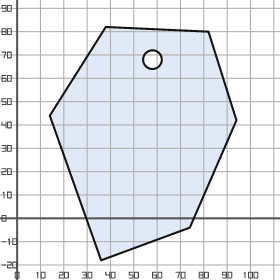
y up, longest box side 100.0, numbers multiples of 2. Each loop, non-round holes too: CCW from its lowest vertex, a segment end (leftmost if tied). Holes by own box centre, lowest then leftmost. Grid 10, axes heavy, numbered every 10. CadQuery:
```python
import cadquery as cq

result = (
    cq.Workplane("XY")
    .moveTo(36.0, -18.0)
    .lineTo(74.0, -4.0)
    .lineTo(94.0, 42.0)
    .lineTo(82.0, 80.0)
    .lineTo(38.0, 82.0)
    .lineTo(14.0, 44.0)
    .close()
    .moveTo(58.0, 68.0)
    .circle(4.0)
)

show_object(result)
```